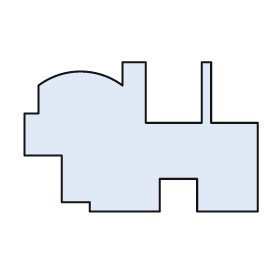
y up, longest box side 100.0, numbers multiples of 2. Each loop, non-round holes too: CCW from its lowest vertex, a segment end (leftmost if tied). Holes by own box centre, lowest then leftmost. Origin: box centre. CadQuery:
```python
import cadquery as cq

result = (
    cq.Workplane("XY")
    .moveTo(-22.0, -32.0)
    .lineTo(8.0, -32.0)
    .lineTo(8.0, -18.0)
    .lineTo(24.0, -18.0)
    .lineTo(24.0, -32.0)
    .lineTo(50.0, -32.0)
    .lineTo(50.0, 6.0)
    .lineTo(30.0, 6.0)
    .lineTo(30.0, 32.0)
    .lineTo(26.0, 32.0)
    .lineTo(26.0, 6.0)
    .lineTo(2.0, 6.0)
    .lineTo(2.0, 32.0)
    .lineTo(-8.0, 32.0)
    .lineTo(-8.0, 22.0)
    .threePointArc((-26.0, 28.0), (-44.0, 22.0))
    .lineTo(-44.0, 10.0)
    .lineTo(-50.0, 10.0)
    .lineTo(-50.0, -8.0)
    .lineTo(-34.0, -8.0)
    .lineTo(-34.0, -28.0)
    .lineTo(-22.0, -28.0)
    .close()
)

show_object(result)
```